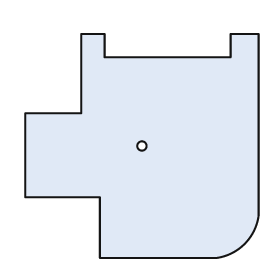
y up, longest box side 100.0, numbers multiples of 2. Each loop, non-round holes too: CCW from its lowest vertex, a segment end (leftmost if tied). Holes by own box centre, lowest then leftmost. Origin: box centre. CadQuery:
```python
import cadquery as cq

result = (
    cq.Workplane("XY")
    .moveTo(-18.0, -48.0)
    .lineTo(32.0, -48.0)
    .threePointArc((44.0, -42.0), (50.0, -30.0))
    .lineTo(50.0, 48.0)
    .lineTo(38.0, 48.0)
    .lineTo(38.0, 38.0)
    .lineTo(-16.0, 38.0)
    .lineTo(-16.0, 48.0)
    .lineTo(-26.0, 48.0)
    .lineTo(-26.0, 14.0)
    .lineTo(-50.0, 14.0)
    .lineTo(-50.0, -22.0)
    .lineTo(-18.0, -22.0)
    .close()
    .moveTo(0.0, 0.0)
    .circle(2.0)
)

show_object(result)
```